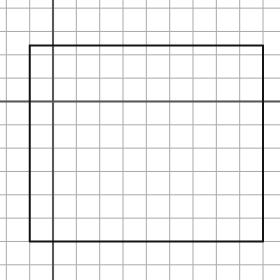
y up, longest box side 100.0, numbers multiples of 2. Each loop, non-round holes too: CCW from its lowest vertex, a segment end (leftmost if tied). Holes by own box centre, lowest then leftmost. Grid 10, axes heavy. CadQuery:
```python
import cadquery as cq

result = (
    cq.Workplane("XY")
    .moveTo(-10.0, -60.0)
    .lineTo(90.0, -60.0)
    .lineTo(90.0, 24.0)
    .lineTo(-10.0, 24.0)
    .close()
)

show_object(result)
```